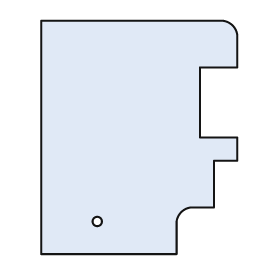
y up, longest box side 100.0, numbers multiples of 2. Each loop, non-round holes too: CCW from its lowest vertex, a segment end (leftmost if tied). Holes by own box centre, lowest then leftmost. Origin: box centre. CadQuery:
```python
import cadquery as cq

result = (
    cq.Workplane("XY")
    .moveTo(-42.0, -50.0)
    .lineTo(16.0, -50.0)
    .lineTo(16.0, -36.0)
    .threePointArc((18.0, -32.0), (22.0, -30.0))
    .lineTo(32.0, -30.0)
    .lineTo(32.0, -10.0)
    .lineTo(42.0, -10.0)
    .lineTo(42.0, 0.0)
    .lineTo(26.0, 0.0)
    .lineTo(26.0, 30.0)
    .lineTo(42.0, 30.0)
    .lineTo(42.0, 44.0)
    .threePointArc((40.0, 48.0), (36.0, 50.0))
    .lineTo(-42.0, 50.0)
    .close()
    .moveTo(-18.0, -36.0)
    .circle(2.0)
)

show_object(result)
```